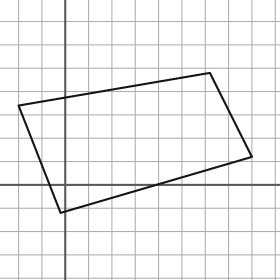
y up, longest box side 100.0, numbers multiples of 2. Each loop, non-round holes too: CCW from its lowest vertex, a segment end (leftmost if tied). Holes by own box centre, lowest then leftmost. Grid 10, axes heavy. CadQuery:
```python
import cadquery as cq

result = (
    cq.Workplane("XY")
    .moveTo(-2.0, -12.0)
    .lineTo(80.0, 12.0)
    .lineTo(62.0, 48.0)
    .lineTo(-20.0, 34.0)
    .close()
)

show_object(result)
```